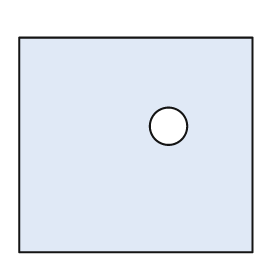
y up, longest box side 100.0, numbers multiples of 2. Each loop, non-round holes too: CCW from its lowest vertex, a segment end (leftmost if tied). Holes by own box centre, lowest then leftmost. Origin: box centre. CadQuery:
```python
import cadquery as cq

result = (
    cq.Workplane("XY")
    .moveTo(-50.0, -46.0)
    .lineTo(50.0, -46.0)
    .lineTo(50.0, 46.0)
    .lineTo(-50.0, 46.0)
    .close()
    .moveTo(14.0, 8.0)
    .circle(8.0)
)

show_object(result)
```